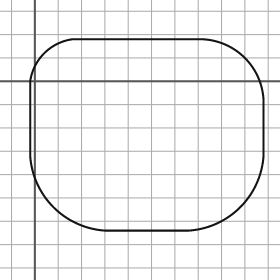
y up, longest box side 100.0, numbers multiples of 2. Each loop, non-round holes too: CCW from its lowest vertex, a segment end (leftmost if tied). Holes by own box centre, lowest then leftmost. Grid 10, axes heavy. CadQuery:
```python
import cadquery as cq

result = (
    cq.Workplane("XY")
    .moveTo(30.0, -64.0)
    .lineTo(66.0, -64.0)
    .threePointArc((88.0, -54.0), (98.0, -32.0))
    .lineTo(98.0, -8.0)
    .threePointArc((90.0, 10.0), (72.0, 18.0))
    .lineTo(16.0, 18.0)
    .threePointArc((4.0, 12.0), (-2.0, 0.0))
    .lineTo(-2.0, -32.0)
    .threePointArc((8.0, -54.0), (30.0, -64.0))
    .close()
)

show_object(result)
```